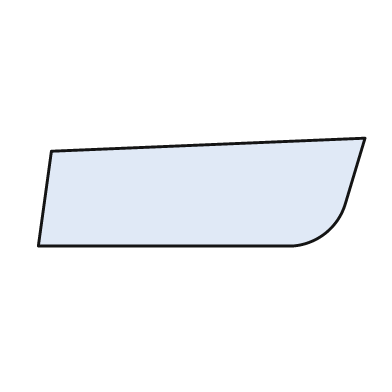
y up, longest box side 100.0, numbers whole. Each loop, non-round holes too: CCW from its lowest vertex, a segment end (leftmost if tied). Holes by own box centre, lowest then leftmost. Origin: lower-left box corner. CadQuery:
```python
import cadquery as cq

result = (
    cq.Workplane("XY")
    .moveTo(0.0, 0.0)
    .lineTo(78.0, 0.0)
    .threePointArc((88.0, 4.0), (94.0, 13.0))
    .lineTo(100.0, 33.0)
    .lineTo(4.0, 29.0)
    .close()
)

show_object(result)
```